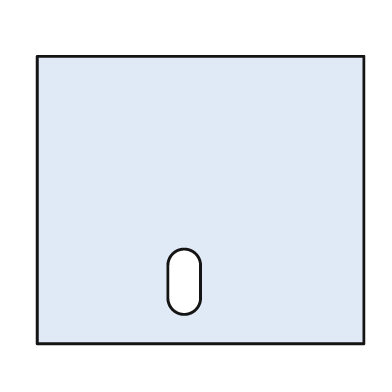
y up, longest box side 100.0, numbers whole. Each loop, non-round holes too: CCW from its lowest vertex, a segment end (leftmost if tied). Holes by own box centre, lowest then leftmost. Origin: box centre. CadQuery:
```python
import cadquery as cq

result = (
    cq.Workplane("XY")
    .moveTo(-50.0, -44.0)
    .lineTo(50.0, -44.0)
    .lineTo(50.0, 44.0)
    .lineTo(-50.0, 44.0)
    .close()
    .moveTo(-10.0, -30.0)
    .threePointArc((-5.0, -35.0), (0.0, -30.0))
    .lineTo(0.0, -20.0)
    .threePointArc((-5.0, -15.0), (-10.0, -20.0))
    .close()
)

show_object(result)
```